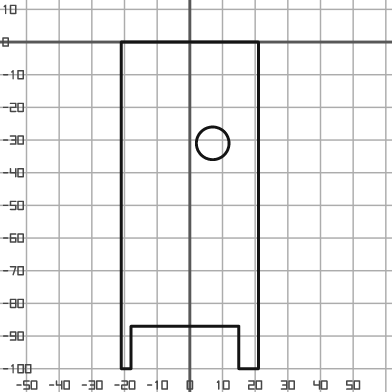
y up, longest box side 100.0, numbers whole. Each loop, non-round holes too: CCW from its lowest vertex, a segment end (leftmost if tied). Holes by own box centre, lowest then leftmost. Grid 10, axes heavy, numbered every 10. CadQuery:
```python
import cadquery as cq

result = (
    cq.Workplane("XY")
    .moveTo(-21.0, -100.0)
    .lineTo(-18.0, -100.0)
    .lineTo(-18.0, -87.0)
    .lineTo(15.0, -87.0)
    .lineTo(15.0, -100.0)
    .lineTo(21.0, -100.0)
    .lineTo(21.0, 0.0)
    .lineTo(-21.0, 0.0)
    .close()
    .moveTo(7.0, -31.0)
    .circle(5.0)
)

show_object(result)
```